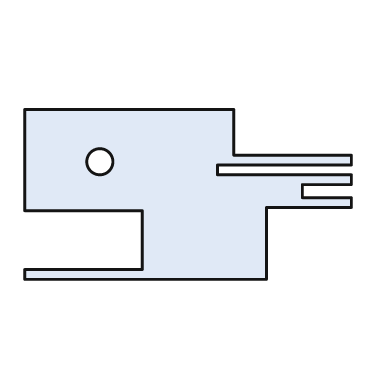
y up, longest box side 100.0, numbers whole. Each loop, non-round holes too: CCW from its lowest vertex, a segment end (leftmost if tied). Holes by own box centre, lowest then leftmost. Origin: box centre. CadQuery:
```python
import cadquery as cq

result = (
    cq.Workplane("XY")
    .moveTo(-50.0, -26.0)
    .lineTo(24.0, -26.0)
    .lineTo(24.0, -4.0)
    .lineTo(50.0, -4.0)
    .lineTo(50.0, -1.0)
    .lineTo(35.0, -1.0)
    .lineTo(35.0, 3.0)
    .lineTo(50.0, 3.0)
    .lineTo(50.0, 6.0)
    .lineTo(9.0, 6.0)
    .lineTo(9.0, 9.0)
    .lineTo(50.0, 9.0)
    .lineTo(50.0, 12.0)
    .lineTo(14.0, 12.0)
    .lineTo(14.0, 26.0)
    .lineTo(-50.0, 26.0)
    .lineTo(-50.0, -5.0)
    .lineTo(-14.0, -5.0)
    .lineTo(-14.0, -23.0)
    .lineTo(-50.0, -23.0)
    .close()
    .moveTo(-27.0, 10.0)
    .circle(4.0)
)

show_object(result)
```